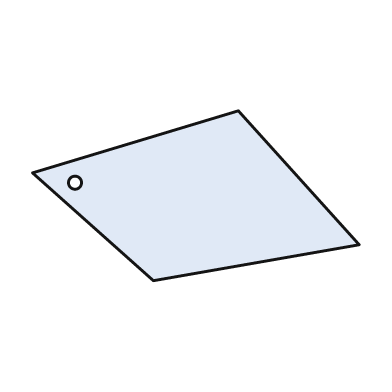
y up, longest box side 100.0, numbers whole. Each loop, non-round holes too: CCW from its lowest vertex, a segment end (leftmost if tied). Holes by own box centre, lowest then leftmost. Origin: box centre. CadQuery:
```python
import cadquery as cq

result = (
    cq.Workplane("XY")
    .moveTo(-13.0, -26.0)
    .lineTo(50.0, -15.0)
    .lineTo(13.0, 26.0)
    .lineTo(-50.0, 7.0)
    .close()
    .moveTo(-37.0, 4.0)
    .circle(2.0)
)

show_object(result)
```